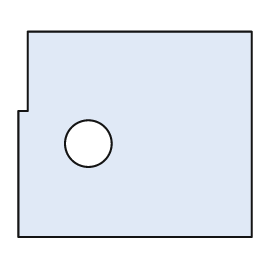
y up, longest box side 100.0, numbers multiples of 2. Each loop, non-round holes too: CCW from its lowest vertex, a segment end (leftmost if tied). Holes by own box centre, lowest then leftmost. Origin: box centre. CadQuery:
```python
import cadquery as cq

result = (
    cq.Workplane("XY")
    .moveTo(-50.0, -44.0)
    .lineTo(50.0, -44.0)
    .lineTo(50.0, 44.0)
    .lineTo(-46.0, 44.0)
    .lineTo(-46.0, 10.0)
    .lineTo(-50.0, 10.0)
    .close()
    .moveTo(-20.0, -4.0)
    .circle(10.0)
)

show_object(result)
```